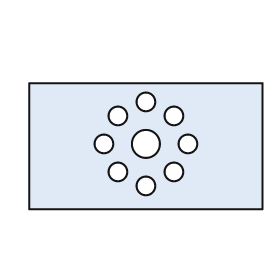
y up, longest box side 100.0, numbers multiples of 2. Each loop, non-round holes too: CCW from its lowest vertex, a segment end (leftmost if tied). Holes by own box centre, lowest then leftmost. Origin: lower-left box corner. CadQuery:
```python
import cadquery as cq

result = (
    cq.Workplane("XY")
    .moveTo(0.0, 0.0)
    .lineTo(100.0, 0.0)
    .lineTo(100.0, 54.0)
    .lineTo(0.0, 54.0)
    .close()
    .moveTo(50.0, 10.0)
    .circle(4.0)
    .moveTo(38.0, 16.0)
    .circle(4.0)
    .moveTo(62.0, 16.0)
    .circle(4.0)
    .moveTo(32.0, 28.0)
    .circle(4.0)
    .moveTo(50.0, 28.0)
    .circle(6.0)
    .moveTo(68.0, 28.0)
    .circle(4.0)
    .moveTo(38.0, 40.0)
    .circle(4.0)
    .moveTo(62.0, 40.0)
    .circle(4.0)
    .moveTo(50.0, 46.0)
    .circle(4.0)
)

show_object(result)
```